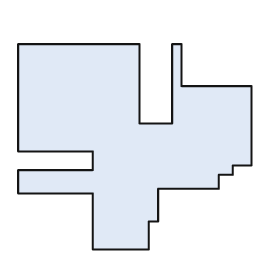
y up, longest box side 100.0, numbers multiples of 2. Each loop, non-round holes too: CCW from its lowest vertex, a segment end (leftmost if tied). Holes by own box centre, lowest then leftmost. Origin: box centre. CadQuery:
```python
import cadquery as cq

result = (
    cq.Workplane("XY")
    .moveTo(-18.0, -44.0)
    .lineTo(6.0, -44.0)
    .lineTo(6.0, -32.0)
    .lineTo(10.0, -32.0)
    .lineTo(10.0, -18.0)
    .lineTo(36.0, -18.0)
    .lineTo(36.0, -12.0)
    .lineTo(42.0, -12.0)
    .lineTo(42.0, -8.0)
    .lineTo(50.0, -8.0)
    .lineTo(50.0, 26.0)
    .lineTo(20.0, 26.0)
    .lineTo(20.0, 44.0)
    .lineTo(16.0, 44.0)
    .lineTo(16.0, 10.0)
    .lineTo(2.0, 10.0)
    .lineTo(2.0, 44.0)
    .lineTo(-50.0, 44.0)
    .lineTo(-50.0, -2.0)
    .lineTo(-18.0, -2.0)
    .lineTo(-18.0, -10.0)
    .lineTo(-50.0, -10.0)
    .lineTo(-50.0, -20.0)
    .lineTo(-18.0, -20.0)
    .close()
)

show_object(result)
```